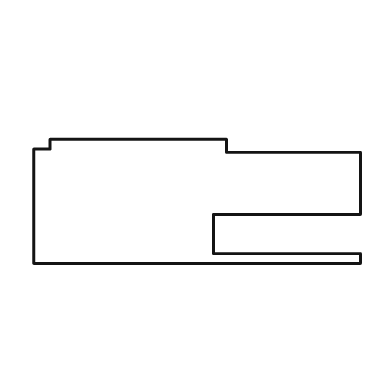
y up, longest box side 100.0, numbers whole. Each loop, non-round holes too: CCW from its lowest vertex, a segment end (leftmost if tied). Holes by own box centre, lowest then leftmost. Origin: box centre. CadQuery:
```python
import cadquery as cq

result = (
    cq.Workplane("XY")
    .moveTo(-50.0, -19.0)
    .lineTo(50.0, -19.0)
    .lineTo(50.0, -16.0)
    .lineTo(5.0, -16.0)
    .lineTo(5.0, -4.0)
    .lineTo(50.0, -4.0)
    .lineTo(50.0, 15.0)
    .lineTo(9.0, 15.0)
    .lineTo(9.0, 19.0)
    .lineTo(-45.0, 19.0)
    .lineTo(-45.0, 16.0)
    .lineTo(-50.0, 16.0)
    .close()
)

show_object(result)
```